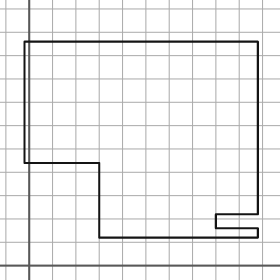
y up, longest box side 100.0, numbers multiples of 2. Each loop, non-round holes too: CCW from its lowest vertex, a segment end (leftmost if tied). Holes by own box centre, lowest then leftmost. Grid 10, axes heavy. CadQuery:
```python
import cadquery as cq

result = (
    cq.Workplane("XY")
    .moveTo(30.0, 12.0)
    .lineTo(98.0, 12.0)
    .lineTo(98.0, 16.0)
    .lineTo(80.0, 16.0)
    .lineTo(80.0, 22.0)
    .lineTo(98.0, 22.0)
    .lineTo(98.0, 96.0)
    .lineTo(-2.0, 96.0)
    .lineTo(-2.0, 44.0)
    .lineTo(30.0, 44.0)
    .close()
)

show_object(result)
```